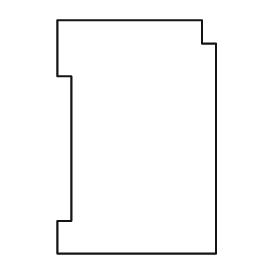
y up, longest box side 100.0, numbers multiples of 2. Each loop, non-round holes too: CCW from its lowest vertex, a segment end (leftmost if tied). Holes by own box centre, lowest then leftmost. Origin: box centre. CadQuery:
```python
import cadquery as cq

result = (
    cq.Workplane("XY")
    .moveTo(-34.0, -50.0)
    .lineTo(34.0, -50.0)
    .lineTo(34.0, 40.0)
    .lineTo(28.0, 40.0)
    .lineTo(28.0, 50.0)
    .lineTo(-34.0, 50.0)
    .lineTo(-34.0, 26.0)
    .lineTo(-28.0, 26.0)
    .lineTo(-28.0, -36.0)
    .lineTo(-34.0, -36.0)
    .close()
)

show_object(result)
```